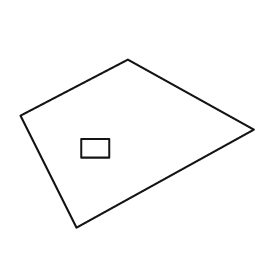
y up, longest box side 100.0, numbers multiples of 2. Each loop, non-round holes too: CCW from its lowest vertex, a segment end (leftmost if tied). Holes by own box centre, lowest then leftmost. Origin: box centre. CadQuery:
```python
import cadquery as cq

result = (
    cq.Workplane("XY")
    .moveTo(-26.0, -36.0)
    .lineTo(50.0, 6.0)
    .lineTo(-4.0, 36.0)
    .lineTo(-50.0, 12.0)
    .close()
    .moveTo(-24.0, -6.0)
    .lineTo(-12.0, -6.0)
    .lineTo(-12.0, 2.0)
    .lineTo(-24.0, 2.0)
    .close()
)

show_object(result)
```